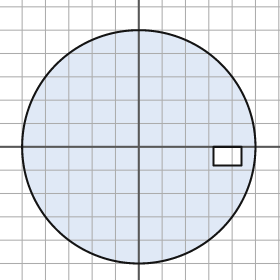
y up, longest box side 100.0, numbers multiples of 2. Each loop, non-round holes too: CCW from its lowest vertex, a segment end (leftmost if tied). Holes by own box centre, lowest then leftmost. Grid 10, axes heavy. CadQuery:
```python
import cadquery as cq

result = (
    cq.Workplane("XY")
    .moveTo(0.0, 0.0)
    .circle(50.0)
    .moveTo(32.0, -8.0)
    .lineTo(44.0, -8.0)
    .lineTo(44.0, 0.0)
    .lineTo(32.0, 0.0)
    .close()
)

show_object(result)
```